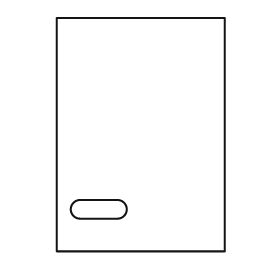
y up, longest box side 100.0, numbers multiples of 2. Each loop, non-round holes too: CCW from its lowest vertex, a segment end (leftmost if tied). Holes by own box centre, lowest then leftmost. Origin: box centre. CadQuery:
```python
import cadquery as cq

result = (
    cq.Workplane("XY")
    .moveTo(-36.0, -50.0)
    .lineTo(36.0, -50.0)
    .lineTo(36.0, 50.0)
    .lineTo(-36.0, 50.0)
    .close()
    .moveTo(-26.0, -36.0)
    .lineTo(-10.0, -36.0)
    .threePointArc((-6.0, -32.0), (-10.0, -28.0))
    .lineTo(-26.0, -28.0)
    .threePointArc((-30.0, -32.0), (-26.0, -36.0))
    .close()
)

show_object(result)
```